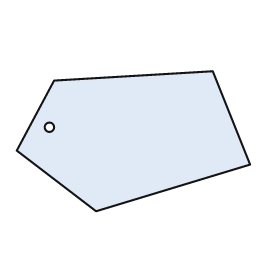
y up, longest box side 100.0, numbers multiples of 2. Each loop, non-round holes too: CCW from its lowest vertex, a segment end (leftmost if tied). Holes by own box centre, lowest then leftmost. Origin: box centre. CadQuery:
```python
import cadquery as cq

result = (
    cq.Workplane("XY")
    .moveTo(-16.0, -30.0)
    .lineTo(50.0, -10.0)
    .lineTo(34.0, 30.0)
    .lineTo(-34.0, 26.0)
    .lineTo(-50.0, -4.0)
    .close()
    .moveTo(-36.0, 6.0)
    .circle(2.0)
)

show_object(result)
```